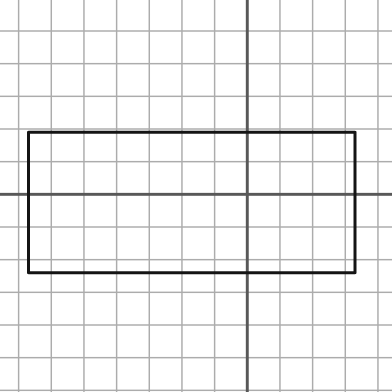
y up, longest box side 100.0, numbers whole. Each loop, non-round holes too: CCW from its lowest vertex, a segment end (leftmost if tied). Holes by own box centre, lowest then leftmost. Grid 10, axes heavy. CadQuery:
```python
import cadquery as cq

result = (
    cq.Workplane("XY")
    .moveTo(-67.0, -24.0)
    .lineTo(33.0, -24.0)
    .lineTo(33.0, 19.0)
    .lineTo(-67.0, 19.0)
    .close()
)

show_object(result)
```